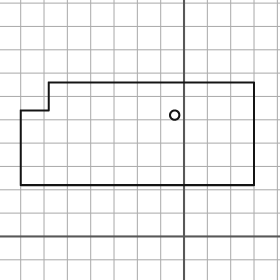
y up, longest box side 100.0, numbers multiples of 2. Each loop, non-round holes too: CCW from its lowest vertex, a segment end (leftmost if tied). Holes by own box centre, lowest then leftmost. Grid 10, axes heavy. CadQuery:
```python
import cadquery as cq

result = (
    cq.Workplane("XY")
    .moveTo(-70.0, 22.0)
    .lineTo(30.0, 22.0)
    .lineTo(30.0, 66.0)
    .lineTo(-58.0, 66.0)
    .lineTo(-58.0, 54.0)
    .lineTo(-70.0, 54.0)
    .close()
    .moveTo(-4.0, 52.0)
    .circle(2.0)
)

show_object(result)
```